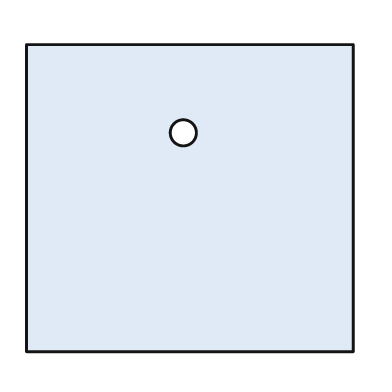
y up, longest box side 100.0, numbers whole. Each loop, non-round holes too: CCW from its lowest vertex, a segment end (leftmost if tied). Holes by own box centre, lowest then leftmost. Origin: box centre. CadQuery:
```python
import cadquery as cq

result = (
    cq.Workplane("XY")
    .moveTo(-50.0, -47.0)
    .lineTo(50.0, -47.0)
    .lineTo(50.0, 47.0)
    .lineTo(-50.0, 47.0)
    .close()
    .moveTo(-2.0, 20.0)
    .circle(4.0)
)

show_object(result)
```